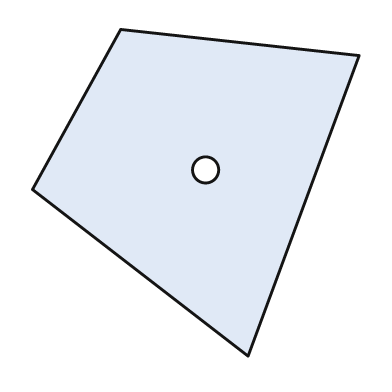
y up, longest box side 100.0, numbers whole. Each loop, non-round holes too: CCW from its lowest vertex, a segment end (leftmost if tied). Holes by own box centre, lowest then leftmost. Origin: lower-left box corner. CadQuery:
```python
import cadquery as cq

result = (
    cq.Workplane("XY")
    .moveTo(66.0, 0.0)
    .lineTo(100.0, 92.0)
    .lineTo(27.0, 100.0)
    .lineTo(0.0, 51.0)
    .close()
    .moveTo(53.0, 57.0)
    .circle(4.0)
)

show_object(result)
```